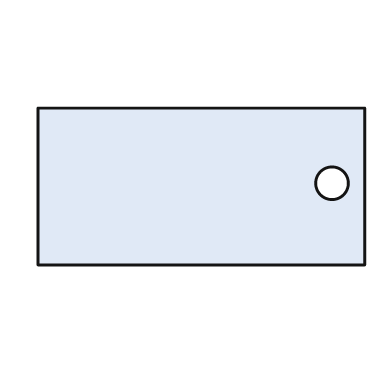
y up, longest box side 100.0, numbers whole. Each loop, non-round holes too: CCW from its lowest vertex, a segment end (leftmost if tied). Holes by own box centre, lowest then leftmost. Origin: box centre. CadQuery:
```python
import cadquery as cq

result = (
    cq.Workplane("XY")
    .moveTo(-50.0, -24.0)
    .lineTo(50.0, -24.0)
    .lineTo(50.0, 24.0)
    .lineTo(-50.0, 24.0)
    .close()
    .moveTo(40.0, 1.0)
    .circle(5.0)
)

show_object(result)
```